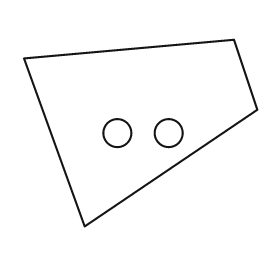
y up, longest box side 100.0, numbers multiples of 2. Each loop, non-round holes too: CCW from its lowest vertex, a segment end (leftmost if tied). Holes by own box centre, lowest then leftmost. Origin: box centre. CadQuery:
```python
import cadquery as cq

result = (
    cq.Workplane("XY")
    .moveTo(-24.0, -40.0)
    .lineTo(50.0, 10.0)
    .lineTo(40.0, 40.0)
    .lineTo(-50.0, 32.0)
    .close()
    .moveTo(-10.0, 0.0)
    .circle(6.0)
    .moveTo(12.0, 0.0)
    .circle(6.0)
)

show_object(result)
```